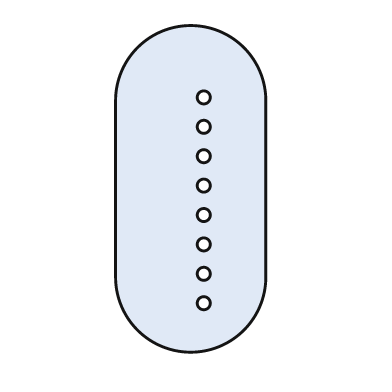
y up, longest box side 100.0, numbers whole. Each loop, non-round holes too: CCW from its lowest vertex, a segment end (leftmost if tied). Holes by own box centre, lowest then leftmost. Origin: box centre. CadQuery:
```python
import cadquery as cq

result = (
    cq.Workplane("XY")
    .moveTo(-23.0, -27.0)
    .threePointArc((0.0, -50.0), (23.0, -27.0))
    .lineTo(23.0, 27.0)
    .threePointArc((0.0, 50.0), (-23.0, 27.0))
    .close()
    .moveTo(4.0, -35.0)
    .circle(2.0)
    .moveTo(4.0, -26.0)
    .circle(2.0)
    .moveTo(4.0, -17.0)
    .circle(2.0)
    .moveTo(4.0, -8.0)
    .circle(2.0)
    .moveTo(4.0, 1.0)
    .circle(2.0)
    .moveTo(4.0, 10.0)
    .circle(2.0)
    .moveTo(4.0, 19.0)
    .circle(2.0)
    .moveTo(4.0, 28.0)
    .circle(2.0)
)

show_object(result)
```